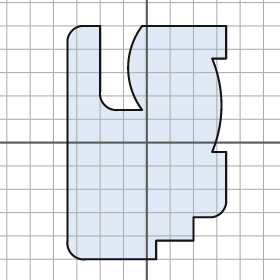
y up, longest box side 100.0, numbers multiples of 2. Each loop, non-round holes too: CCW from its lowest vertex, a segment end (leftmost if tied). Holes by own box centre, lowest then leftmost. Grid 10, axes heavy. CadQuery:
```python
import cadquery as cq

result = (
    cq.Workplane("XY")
    .moveTo(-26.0, -50.0)
    .lineTo(4.0, -50.0)
    .lineTo(4.0, -42.0)
    .lineTo(20.0, -42.0)
    .lineTo(20.0, -32.0)
    .lineTo(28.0, -32.0)
    .threePointArc((32.0, -30.0), (34.0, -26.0))
    .lineTo(34.0, -4.0)
    .lineTo(28.0, -4.0)
    .threePointArc((32.0, 16.0), (28.0, 36.0))
    .lineTo(34.0, 36.0)
    .lineTo(34.0, 50.0)
    .lineTo(-2.0, 50.0)
    .threePointArc((-8.0, 32.0), (-2.0, 14.0))
    .lineTo(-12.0, 14.0)
    .threePointArc((-18.0, 16.0), (-20.0, 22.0))
    .lineTo(-20.0, 50.0)
    .lineTo(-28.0, 50.0)
    .threePointArc((-32.0, 48.0), (-34.0, 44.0))
    .lineTo(-34.0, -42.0)
    .threePointArc((-32.0, -48.0), (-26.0, -50.0))
    .close()
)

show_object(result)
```